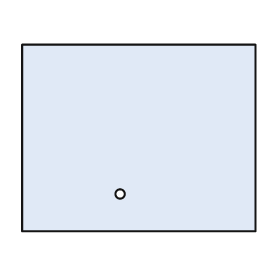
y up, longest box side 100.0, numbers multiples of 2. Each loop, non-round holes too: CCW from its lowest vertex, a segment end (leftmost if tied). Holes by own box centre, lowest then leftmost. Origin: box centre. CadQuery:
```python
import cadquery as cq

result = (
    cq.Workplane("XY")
    .moveTo(-50.0, -40.0)
    .lineTo(50.0, -40.0)
    .lineTo(50.0, 40.0)
    .lineTo(-50.0, 40.0)
    .close()
    .moveTo(-8.0, -24.0)
    .circle(2.0)
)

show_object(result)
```